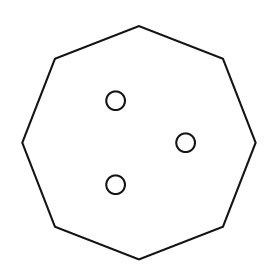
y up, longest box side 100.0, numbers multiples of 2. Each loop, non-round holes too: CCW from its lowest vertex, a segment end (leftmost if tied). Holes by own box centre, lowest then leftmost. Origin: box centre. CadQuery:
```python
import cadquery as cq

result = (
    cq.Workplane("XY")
    .moveTo(0.0, -50.0)
    .lineTo(36.0, -36.0)
    .lineTo(50.0, 0.0)
    .lineTo(36.0, 36.0)
    .lineTo(0.0, 50.0)
    .lineTo(-36.0, 36.0)
    .lineTo(-50.0, 0.0)
    .lineTo(-36.0, -36.0)
    .close()
    .moveTo(-10.0, -18.0)
    .circle(4.0)
    .moveTo(20.0, 0.0)
    .circle(4.0)
    .moveTo(-10.0, 18.0)
    .circle(4.0)
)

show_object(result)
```